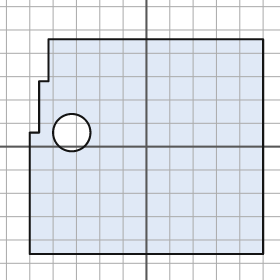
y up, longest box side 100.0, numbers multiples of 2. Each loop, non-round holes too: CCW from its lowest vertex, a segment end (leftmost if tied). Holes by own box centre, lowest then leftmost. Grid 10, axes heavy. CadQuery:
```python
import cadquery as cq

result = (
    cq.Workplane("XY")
    .moveTo(-50.0, -46.0)
    .lineTo(50.0, -46.0)
    .lineTo(50.0, 46.0)
    .lineTo(-42.0, 46.0)
    .lineTo(-42.0, 28.0)
    .lineTo(-46.0, 28.0)
    .lineTo(-46.0, 6.0)
    .lineTo(-50.0, 6.0)
    .close()
    .moveTo(-32.0, 6.0)
    .circle(8.0)
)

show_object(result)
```